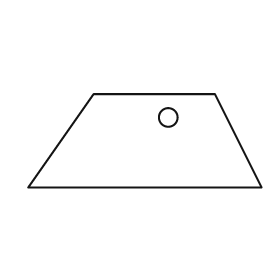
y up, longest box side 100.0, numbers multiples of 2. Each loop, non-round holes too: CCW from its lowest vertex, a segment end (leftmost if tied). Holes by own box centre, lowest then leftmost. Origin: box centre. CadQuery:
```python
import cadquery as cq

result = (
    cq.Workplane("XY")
    .moveTo(-50.0, -20.0)
    .lineTo(50.0, -20.0)
    .lineTo(30.0, 20.0)
    .lineTo(-22.0, 20.0)
    .close()
    .moveTo(10.0, 10.0)
    .circle(4.0)
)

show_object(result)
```